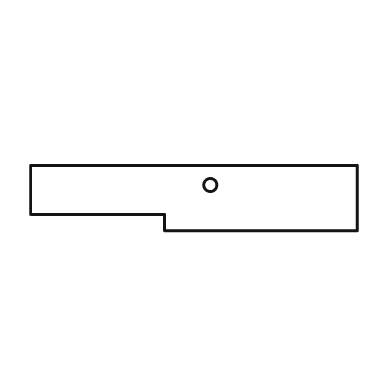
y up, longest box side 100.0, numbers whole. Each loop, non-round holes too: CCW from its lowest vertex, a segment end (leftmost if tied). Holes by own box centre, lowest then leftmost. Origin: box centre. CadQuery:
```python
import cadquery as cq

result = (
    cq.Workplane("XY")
    .moveTo(-9.0, -10.0)
    .lineTo(50.0, -10.0)
    .lineTo(50.0, 10.0)
    .lineTo(-50.0, 10.0)
    .lineTo(-50.0, -5.0)
    .lineTo(-9.0, -5.0)
    .close()
    .moveTo(5.0, 4.0)
    .circle(2.0)
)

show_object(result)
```